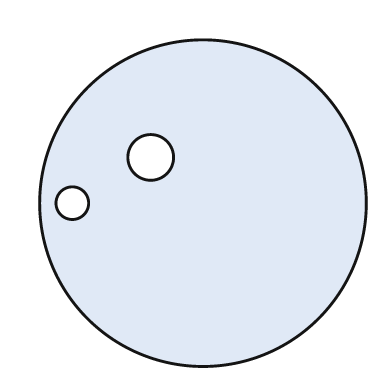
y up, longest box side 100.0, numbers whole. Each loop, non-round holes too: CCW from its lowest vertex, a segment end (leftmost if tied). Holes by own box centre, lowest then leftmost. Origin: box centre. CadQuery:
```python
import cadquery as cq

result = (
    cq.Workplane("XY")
    .moveTo(0.0, 0.0)
    .circle(50.0)
    .moveTo(-40.0, 0.0)
    .circle(5.0)
    .moveTo(-16.0, 14.0)
    .circle(7.0)
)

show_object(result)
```